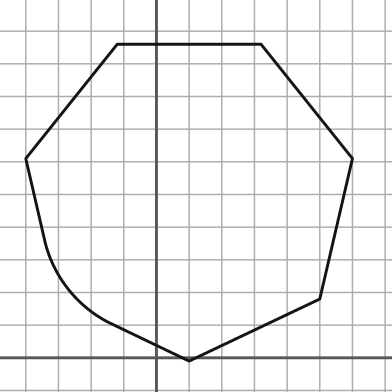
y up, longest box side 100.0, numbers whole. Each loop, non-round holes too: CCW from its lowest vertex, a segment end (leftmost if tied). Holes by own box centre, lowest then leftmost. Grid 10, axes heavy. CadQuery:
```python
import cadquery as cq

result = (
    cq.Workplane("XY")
    .moveTo(10.0, -1.0)
    .lineTo(50.0, 18.0)
    .lineTo(60.0, 61.0)
    .lineTo(32.0, 96.0)
    .lineTo(-12.0, 96.0)
    .lineTo(-40.0, 61.0)
    .lineTo(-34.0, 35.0)
    .threePointArc((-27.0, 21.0), (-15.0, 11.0))
    .close()
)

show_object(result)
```